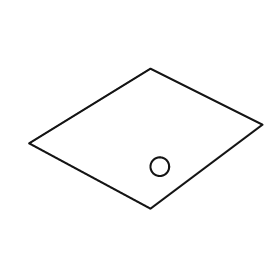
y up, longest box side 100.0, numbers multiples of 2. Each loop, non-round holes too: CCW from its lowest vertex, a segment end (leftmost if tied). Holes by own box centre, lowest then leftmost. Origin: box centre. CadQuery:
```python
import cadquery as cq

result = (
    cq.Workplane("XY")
    .moveTo(2.0, -30.0)
    .lineTo(50.0, 6.0)
    .lineTo(2.0, 30.0)
    .lineTo(-50.0, -2.0)
    .close()
    .moveTo(6.0, -12.0)
    .circle(4.0)
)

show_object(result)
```